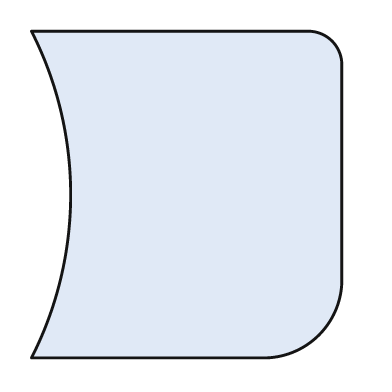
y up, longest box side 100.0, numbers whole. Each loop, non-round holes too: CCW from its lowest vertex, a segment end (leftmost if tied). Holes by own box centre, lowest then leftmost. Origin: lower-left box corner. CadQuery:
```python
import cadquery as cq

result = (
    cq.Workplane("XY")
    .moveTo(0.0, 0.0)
    .lineTo(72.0, 0.0)
    .threePointArc((88.0, 7.0), (95.0, 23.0))
    .lineTo(95.0, 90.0)
    .threePointArc((92.0, 97.0), (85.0, 100.0))
    .lineTo(0.0, 100.0)
    .threePointArc((12.0, 50.0), (0.0, 0.0))
    .close()
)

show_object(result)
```